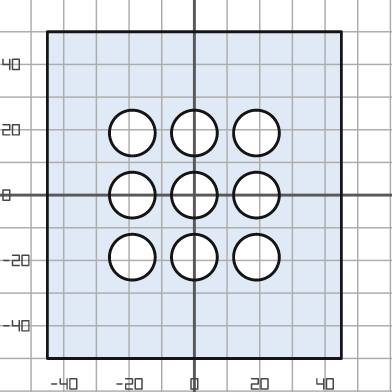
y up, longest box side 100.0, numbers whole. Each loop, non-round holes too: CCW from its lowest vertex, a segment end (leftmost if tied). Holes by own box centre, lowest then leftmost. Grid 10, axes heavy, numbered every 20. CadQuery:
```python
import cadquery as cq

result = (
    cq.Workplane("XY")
    .moveTo(-45.0, -50.0)
    .lineTo(45.0, -50.0)
    .lineTo(45.0, 50.0)
    .lineTo(-45.0, 50.0)
    .close()
    .moveTo(-19.0, -19.0)
    .circle(7.0)
    .moveTo(0.0, -19.0)
    .circle(7.0)
    .moveTo(19.0, -19.0)
    .circle(7.0)
    .moveTo(-19.0, 0.0)
    .circle(7.0)
    .moveTo(0.0, 0.0)
    .circle(7.0)
    .moveTo(19.0, 0.0)
    .circle(7.0)
    .moveTo(-19.0, 19.0)
    .circle(7.0)
    .moveTo(0.0, 19.0)
    .circle(7.0)
    .moveTo(19.0, 19.0)
    .circle(7.0)
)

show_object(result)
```